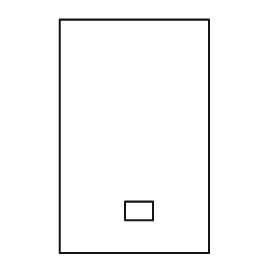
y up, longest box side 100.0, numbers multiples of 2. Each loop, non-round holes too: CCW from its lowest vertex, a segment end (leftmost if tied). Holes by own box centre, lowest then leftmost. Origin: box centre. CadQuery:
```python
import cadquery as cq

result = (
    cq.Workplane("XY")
    .moveTo(-32.0, -50.0)
    .lineTo(32.0, -50.0)
    .lineTo(32.0, 50.0)
    .lineTo(-32.0, 50.0)
    .close()
    .moveTo(-4.0, -36.0)
    .lineTo(8.0, -36.0)
    .lineTo(8.0, -28.0)
    .lineTo(-4.0, -28.0)
    .close()
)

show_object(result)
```